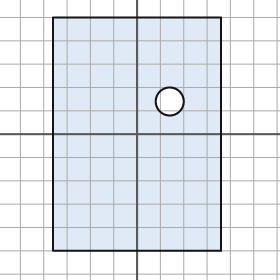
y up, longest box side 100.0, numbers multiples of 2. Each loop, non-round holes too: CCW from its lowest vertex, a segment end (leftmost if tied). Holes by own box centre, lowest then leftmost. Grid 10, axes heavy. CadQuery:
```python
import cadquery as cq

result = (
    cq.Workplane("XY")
    .moveTo(-36.0, -50.0)
    .lineTo(36.0, -50.0)
    .lineTo(36.0, 50.0)
    .lineTo(-36.0, 50.0)
    .close()
    .moveTo(14.0, 14.0)
    .circle(6.0)
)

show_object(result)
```